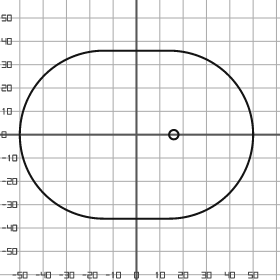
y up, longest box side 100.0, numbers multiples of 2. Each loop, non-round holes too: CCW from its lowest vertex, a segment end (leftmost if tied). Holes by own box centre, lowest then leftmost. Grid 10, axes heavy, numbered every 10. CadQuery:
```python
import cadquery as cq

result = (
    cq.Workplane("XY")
    .moveTo(-14.0, -36.0)
    .lineTo(14.0, -36.0)
    .threePointArc((50.0, 0.0), (14.0, 36.0))
    .lineTo(-14.0, 36.0)
    .threePointArc((-50.0, 0.0), (-14.0, -36.0))
    .close()
    .moveTo(16.0, 0.0)
    .circle(2.0)
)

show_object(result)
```